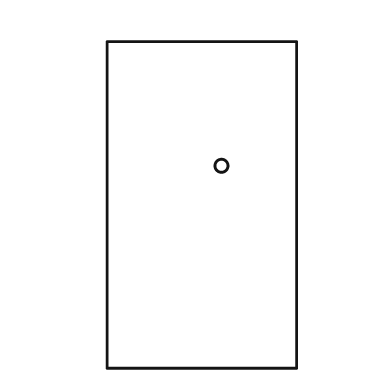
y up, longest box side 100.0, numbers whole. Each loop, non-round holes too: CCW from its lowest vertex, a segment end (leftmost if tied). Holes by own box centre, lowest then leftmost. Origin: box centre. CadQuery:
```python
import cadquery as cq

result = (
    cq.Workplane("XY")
    .moveTo(-29.0, -50.0)
    .lineTo(29.0, -50.0)
    .lineTo(29.0, 50.0)
    .lineTo(-29.0, 50.0)
    .close()
    .moveTo(6.0, 12.0)
    .circle(2.0)
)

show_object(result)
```